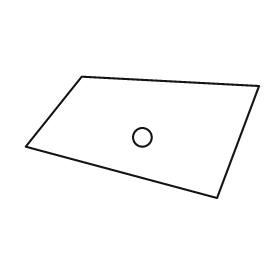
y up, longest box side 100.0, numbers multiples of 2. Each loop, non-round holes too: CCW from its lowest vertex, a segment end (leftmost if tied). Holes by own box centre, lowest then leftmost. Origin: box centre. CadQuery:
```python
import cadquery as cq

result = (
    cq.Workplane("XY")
    .moveTo(32.0, -26.0)
    .lineTo(50.0, 22.0)
    .lineTo(-26.0, 26.0)
    .lineTo(-50.0, -4.0)
    .close()
    .moveTo(0.0, 0.0)
    .circle(4.0)
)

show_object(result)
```